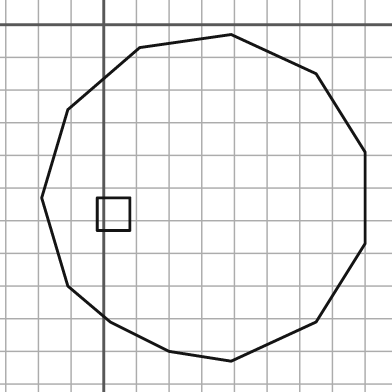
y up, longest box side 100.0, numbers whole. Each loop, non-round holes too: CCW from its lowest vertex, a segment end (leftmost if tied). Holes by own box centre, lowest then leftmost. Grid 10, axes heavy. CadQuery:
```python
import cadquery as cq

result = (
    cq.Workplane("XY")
    .moveTo(39.0, -103.0)
    .lineTo(65.0, -91.0)
    .lineTo(80.0, -67.0)
    .lineTo(80.0, -39.0)
    .lineTo(65.0, -15.0)
    .lineTo(39.0, -3.0)
    .lineTo(11.0, -7.0)
    .lineTo(-11.0, -26.0)
    .lineTo(-19.0, -53.0)
    .lineTo(-11.0, -80.0)
    .lineTo(2.0, -91.0)
    .lineTo(20.0, -100.0)
    .close()
    .moveTo(-2.0, -63.0)
    .lineTo(8.0, -63.0)
    .lineTo(8.0, -53.0)
    .lineTo(-2.0, -53.0)
    .close()
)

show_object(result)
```